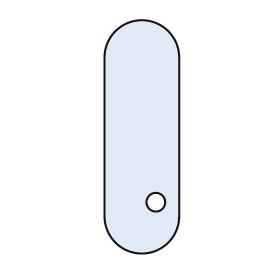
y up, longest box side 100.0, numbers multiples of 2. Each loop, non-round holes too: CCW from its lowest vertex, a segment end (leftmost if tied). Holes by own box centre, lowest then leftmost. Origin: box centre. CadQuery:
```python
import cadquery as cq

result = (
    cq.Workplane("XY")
    .moveTo(-16.0, -34.0)
    .threePointArc((0.0, -50.0), (16.0, -34.0))
    .lineTo(16.0, 34.0)
    .threePointArc((0.0, 50.0), (-16.0, 34.0))
    .close()
    .moveTo(6.0, -28.0)
    .circle(4.0)
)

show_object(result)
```